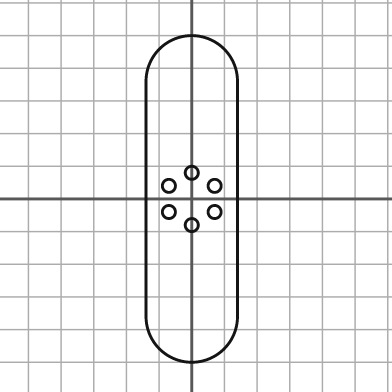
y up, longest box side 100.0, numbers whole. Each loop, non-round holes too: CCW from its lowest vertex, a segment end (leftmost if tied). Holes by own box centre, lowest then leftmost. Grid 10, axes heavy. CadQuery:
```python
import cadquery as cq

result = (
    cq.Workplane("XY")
    .moveTo(-14.0, -36.0)
    .threePointArc((0.0, -50.0), (14.0, -36.0))
    .lineTo(14.0, 36.0)
    .threePointArc((0.0, 50.0), (-14.0, 36.0))
    .close()
    .moveTo(0.0, -8.0)
    .circle(2.0)
    .moveTo(-7.0, -4.0)
    .circle(2.0)
    .moveTo(7.0, -4.0)
    .circle(2.0)
    .moveTo(-7.0, 4.0)
    .circle(2.0)
    .moveTo(7.0, 4.0)
    .circle(2.0)
    .moveTo(0.0, 8.0)
    .circle(2.0)
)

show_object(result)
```